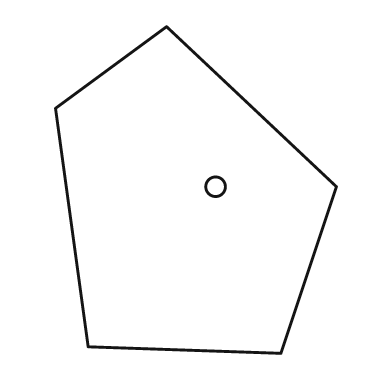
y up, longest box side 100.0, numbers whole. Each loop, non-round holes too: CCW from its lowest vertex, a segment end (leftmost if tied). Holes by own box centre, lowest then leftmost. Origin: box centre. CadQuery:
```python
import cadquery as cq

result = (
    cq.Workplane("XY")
    .moveTo(26.0, -50.0)
    .lineTo(43.0, 1.0)
    .lineTo(-9.0, 50.0)
    .lineTo(-43.0, 25.0)
    .lineTo(-33.0, -48.0)
    .close()
    .moveTo(6.0, 1.0)
    .circle(3.0)
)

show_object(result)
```